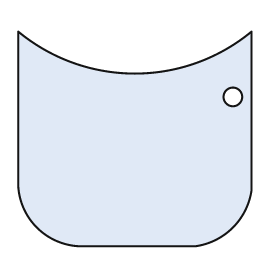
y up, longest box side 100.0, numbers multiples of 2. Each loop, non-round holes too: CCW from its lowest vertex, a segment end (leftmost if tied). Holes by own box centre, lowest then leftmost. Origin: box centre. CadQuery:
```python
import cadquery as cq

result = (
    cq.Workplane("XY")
    .moveTo(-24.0, -46.0)
    .lineTo(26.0, -46.0)
    .threePointArc((42.0, -38.0), (50.0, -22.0))
    .lineTo(50.0, 46.0)
    .threePointArc((0.0, 28.0), (-50.0, 46.0))
    .lineTo(-50.0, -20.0)
    .threePointArc((-42.0, -38.0), (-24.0, -46.0))
    .close()
    .moveTo(42.0, 18.0)
    .circle(4.0)
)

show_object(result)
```